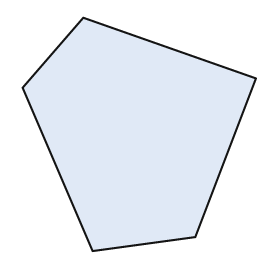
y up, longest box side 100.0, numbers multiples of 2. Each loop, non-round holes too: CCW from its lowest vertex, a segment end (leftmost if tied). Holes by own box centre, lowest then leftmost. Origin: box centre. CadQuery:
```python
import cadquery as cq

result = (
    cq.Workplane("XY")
    .moveTo(-20.0, -50.0)
    .lineTo(24.0, -44.0)
    .lineTo(50.0, 24.0)
    .lineTo(-24.0, 50.0)
    .lineTo(-50.0, 20.0)
    .close()
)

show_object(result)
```